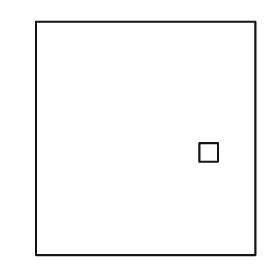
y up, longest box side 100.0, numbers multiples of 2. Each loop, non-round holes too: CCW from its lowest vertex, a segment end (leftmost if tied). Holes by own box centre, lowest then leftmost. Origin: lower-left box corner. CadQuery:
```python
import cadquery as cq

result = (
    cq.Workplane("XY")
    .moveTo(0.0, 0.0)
    .lineTo(94.0, 0.0)
    .lineTo(94.0, 100.0)
    .lineTo(0.0, 100.0)
    .close()
    .moveTo(70.0, 40.0)
    .lineTo(78.0, 40.0)
    .lineTo(78.0, 48.0)
    .lineTo(70.0, 48.0)
    .close()
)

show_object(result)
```